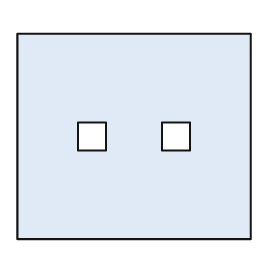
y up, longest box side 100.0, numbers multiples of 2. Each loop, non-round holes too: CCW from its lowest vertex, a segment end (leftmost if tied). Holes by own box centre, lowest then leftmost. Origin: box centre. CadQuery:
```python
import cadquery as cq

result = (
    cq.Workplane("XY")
    .moveTo(-50.0, -44.0)
    .lineTo(50.0, -44.0)
    .lineTo(50.0, 44.0)
    .lineTo(-50.0, 44.0)
    .close()
    .moveTo(-24.0, -6.0)
    .lineTo(-12.0, -6.0)
    .lineTo(-12.0, 6.0)
    .lineTo(-24.0, 6.0)
    .close()
    .moveTo(12.0, -6.0)
    .lineTo(24.0, -6.0)
    .lineTo(24.0, 6.0)
    .lineTo(12.0, 6.0)
    .close()
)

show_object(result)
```